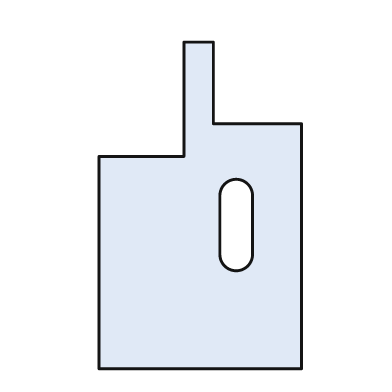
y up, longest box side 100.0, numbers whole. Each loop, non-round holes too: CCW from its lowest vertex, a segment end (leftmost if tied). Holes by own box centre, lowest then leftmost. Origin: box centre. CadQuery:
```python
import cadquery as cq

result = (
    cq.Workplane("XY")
    .moveTo(-31.0, -50.0)
    .lineTo(31.0, -50.0)
    .lineTo(31.0, 25.0)
    .lineTo(4.0, 25.0)
    .lineTo(4.0, 50.0)
    .lineTo(-5.0, 50.0)
    .lineTo(-5.0, 15.0)
    .lineTo(-31.0, 15.0)
    .close()
    .moveTo(6.0, -15.0)
    .threePointArc((11.0, -20.0), (16.0, -15.0))
    .lineTo(16.0, 3.0)
    .threePointArc((11.0, 8.0), (6.0, 3.0))
    .close()
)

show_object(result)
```